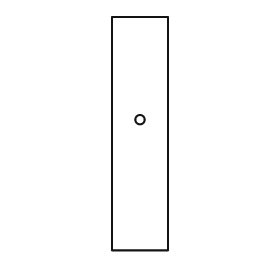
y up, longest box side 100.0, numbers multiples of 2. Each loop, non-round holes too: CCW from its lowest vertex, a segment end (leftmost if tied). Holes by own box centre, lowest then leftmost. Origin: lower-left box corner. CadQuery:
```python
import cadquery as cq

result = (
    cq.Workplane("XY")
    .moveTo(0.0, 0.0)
    .lineTo(24.0, 0.0)
    .lineTo(24.0, 100.0)
    .lineTo(0.0, 100.0)
    .close()
    .moveTo(12.0, 56.0)
    .circle(2.0)
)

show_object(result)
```